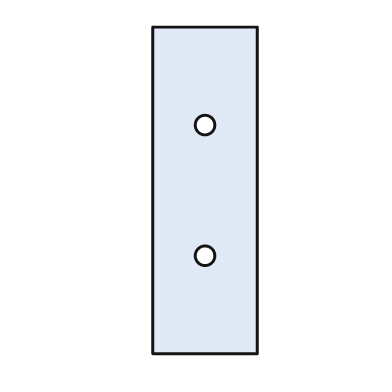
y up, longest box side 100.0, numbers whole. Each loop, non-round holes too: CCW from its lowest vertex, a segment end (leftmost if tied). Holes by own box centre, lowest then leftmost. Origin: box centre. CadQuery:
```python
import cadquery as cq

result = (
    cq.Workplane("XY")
    .moveTo(-16.0, -50.0)
    .lineTo(16.0, -50.0)
    .lineTo(16.0, 50.0)
    .lineTo(-16.0, 50.0)
    .close()
    .moveTo(0.0, -20.0)
    .circle(3.0)
    .moveTo(0.0, 20.0)
    .circle(3.0)
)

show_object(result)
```